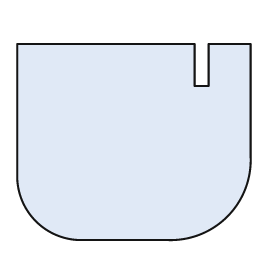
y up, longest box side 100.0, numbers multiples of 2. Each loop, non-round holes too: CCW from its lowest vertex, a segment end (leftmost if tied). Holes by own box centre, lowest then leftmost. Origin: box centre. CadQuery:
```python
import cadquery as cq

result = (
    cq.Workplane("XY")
    .moveTo(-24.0, -42.0)
    .lineTo(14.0, -42.0)
    .threePointArc((40.0, -32.0), (50.0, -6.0))
    .lineTo(50.0, 42.0)
    .lineTo(32.0, 42.0)
    .lineTo(32.0, 24.0)
    .lineTo(26.0, 24.0)
    .lineTo(26.0, 42.0)
    .lineTo(-50.0, 42.0)
    .lineTo(-50.0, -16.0)
    .threePointArc((-42.0, -34.0), (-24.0, -42.0))
    .close()
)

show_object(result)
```